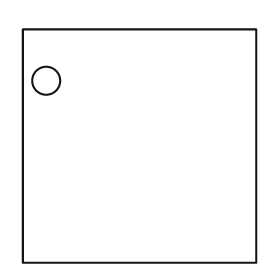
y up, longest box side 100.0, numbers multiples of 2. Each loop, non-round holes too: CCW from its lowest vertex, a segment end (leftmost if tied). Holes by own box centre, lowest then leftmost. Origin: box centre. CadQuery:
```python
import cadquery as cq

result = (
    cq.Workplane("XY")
    .moveTo(-50.0, -50.0)
    .lineTo(50.0, -50.0)
    .lineTo(50.0, 50.0)
    .lineTo(-50.0, 50.0)
    .close()
    .moveTo(-40.0, 28.0)
    .circle(6.0)
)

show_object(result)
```